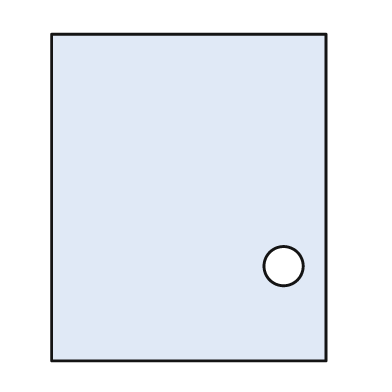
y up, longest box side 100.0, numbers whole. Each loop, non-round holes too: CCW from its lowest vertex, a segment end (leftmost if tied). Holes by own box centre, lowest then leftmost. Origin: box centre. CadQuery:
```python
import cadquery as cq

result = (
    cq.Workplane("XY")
    .moveTo(-42.0, -50.0)
    .lineTo(42.0, -50.0)
    .lineTo(42.0, 50.0)
    .lineTo(-42.0, 50.0)
    .close()
    .moveTo(29.0, -21.0)
    .circle(6.0)
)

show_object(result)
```